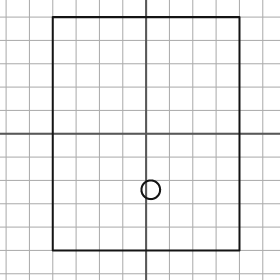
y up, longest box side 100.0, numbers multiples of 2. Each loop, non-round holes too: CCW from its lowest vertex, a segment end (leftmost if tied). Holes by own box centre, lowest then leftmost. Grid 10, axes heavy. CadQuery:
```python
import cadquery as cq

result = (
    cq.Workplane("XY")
    .moveTo(-40.0, -50.0)
    .lineTo(40.0, -50.0)
    .lineTo(40.0, 50.0)
    .lineTo(-40.0, 50.0)
    .close()
    .moveTo(2.0, -24.0)
    .circle(4.0)
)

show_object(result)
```